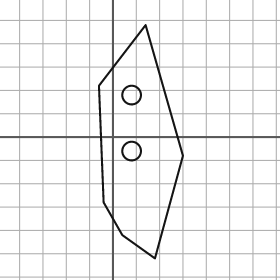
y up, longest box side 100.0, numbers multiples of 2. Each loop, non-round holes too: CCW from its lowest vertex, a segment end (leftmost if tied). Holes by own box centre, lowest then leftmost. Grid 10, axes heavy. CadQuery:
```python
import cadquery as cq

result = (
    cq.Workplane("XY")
    .moveTo(18.0, -52.0)
    .lineTo(30.0, -8.0)
    .lineTo(14.0, 48.0)
    .lineTo(-6.0, 22.0)
    .lineTo(-4.0, -28.0)
    .lineTo(4.0, -42.0)
    .close()
    .moveTo(8.0, -6.0)
    .circle(4.0)
    .moveTo(8.0, 18.0)
    .circle(4.0)
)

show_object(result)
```